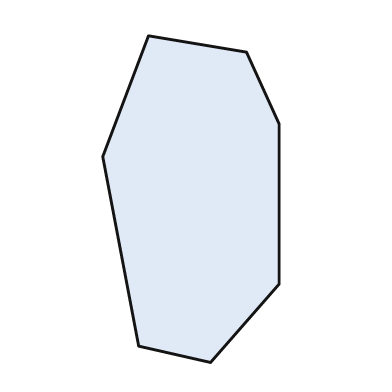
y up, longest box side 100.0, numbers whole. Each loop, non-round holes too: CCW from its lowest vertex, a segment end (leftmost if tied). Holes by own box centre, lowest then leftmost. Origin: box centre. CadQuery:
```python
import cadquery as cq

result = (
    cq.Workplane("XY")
    .moveTo(6.0, -50.0)
    .lineTo(27.0, -26.0)
    .lineTo(27.0, 23.0)
    .lineTo(17.0, 45.0)
    .lineTo(-13.0, 50.0)
    .lineTo(-27.0, 13.0)
    .lineTo(-16.0, -45.0)
    .close()
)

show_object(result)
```